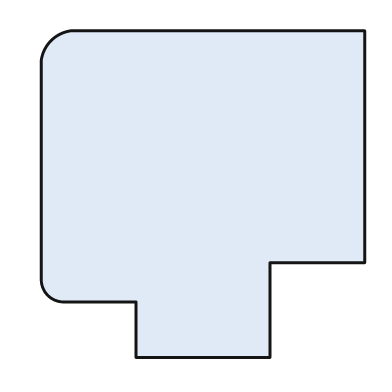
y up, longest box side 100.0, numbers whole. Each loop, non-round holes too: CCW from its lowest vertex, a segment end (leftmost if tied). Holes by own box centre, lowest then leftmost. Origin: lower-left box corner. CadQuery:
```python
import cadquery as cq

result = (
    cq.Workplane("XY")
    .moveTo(29.0, 0.0)
    .lineTo(70.0, 0.0)
    .lineTo(70.0, 29.0)
    .lineTo(99.0, 29.0)
    .lineTo(99.0, 100.0)
    .lineTo(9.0, 100.0)
    .threePointArc((3.0, 97.0), (0.0, 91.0))
    .lineTo(0.0, 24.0)
    .threePointArc((2.0, 19.0), (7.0, 17.0))
    .lineTo(29.0, 17.0)
    .close()
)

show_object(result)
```